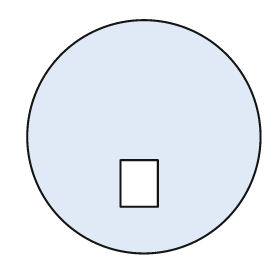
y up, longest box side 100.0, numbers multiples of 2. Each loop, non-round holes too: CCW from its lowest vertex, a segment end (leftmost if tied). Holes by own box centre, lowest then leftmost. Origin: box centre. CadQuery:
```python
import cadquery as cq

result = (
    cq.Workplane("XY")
    .moveTo(0.0, 0.0)
    .circle(50.0)
    .moveTo(-10.0, -30.0)
    .lineTo(6.0, -30.0)
    .lineTo(6.0, -10.0)
    .lineTo(-10.0, -10.0)
    .close()
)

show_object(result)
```